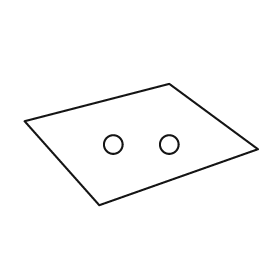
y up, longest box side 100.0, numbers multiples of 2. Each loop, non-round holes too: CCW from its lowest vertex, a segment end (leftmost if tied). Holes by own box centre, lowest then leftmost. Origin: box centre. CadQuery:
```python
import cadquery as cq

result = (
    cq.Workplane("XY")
    .moveTo(-18.0, -26.0)
    .lineTo(50.0, -2.0)
    .lineTo(12.0, 26.0)
    .lineTo(-50.0, 10.0)
    .close()
    .moveTo(-12.0, 0.0)
    .circle(4.0)
    .moveTo(12.0, 0.0)
    .circle(4.0)
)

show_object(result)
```